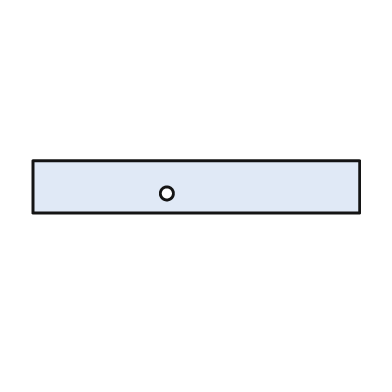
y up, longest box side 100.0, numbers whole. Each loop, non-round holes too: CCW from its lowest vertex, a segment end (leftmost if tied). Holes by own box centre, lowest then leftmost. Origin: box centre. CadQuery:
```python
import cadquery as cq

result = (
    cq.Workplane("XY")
    .moveTo(-50.0, -8.0)
    .lineTo(50.0, -8.0)
    .lineTo(50.0, 8.0)
    .lineTo(-50.0, 8.0)
    .close()
    .moveTo(-9.0, -2.0)
    .circle(2.0)
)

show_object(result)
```